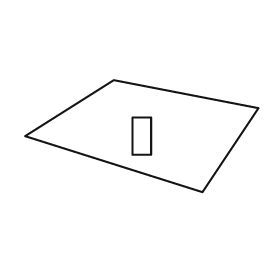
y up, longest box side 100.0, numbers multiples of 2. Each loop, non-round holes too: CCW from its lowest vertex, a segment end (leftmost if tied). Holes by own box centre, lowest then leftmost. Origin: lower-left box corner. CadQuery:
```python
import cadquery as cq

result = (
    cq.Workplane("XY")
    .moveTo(76.0, 0.0)
    .lineTo(100.0, 36.0)
    .lineTo(38.0, 48.0)
    .lineTo(0.0, 24.0)
    .close()
    .moveTo(46.0, 16.0)
    .lineTo(54.0, 16.0)
    .lineTo(54.0, 32.0)
    .lineTo(46.0, 32.0)
    .close()
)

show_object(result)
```